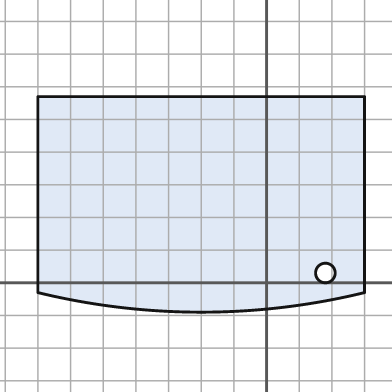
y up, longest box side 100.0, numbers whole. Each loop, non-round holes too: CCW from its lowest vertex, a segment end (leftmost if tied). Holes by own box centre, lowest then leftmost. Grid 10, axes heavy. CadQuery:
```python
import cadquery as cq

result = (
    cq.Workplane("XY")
    .moveTo(-70.0, -3.0)
    .threePointArc((-20.0, -9.0), (30.0, -3.0))
    .lineTo(30.0, 57.0)
    .lineTo(-70.0, 57.0)
    .close()
    .moveTo(18.0, 3.0)
    .circle(3.0)
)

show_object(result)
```